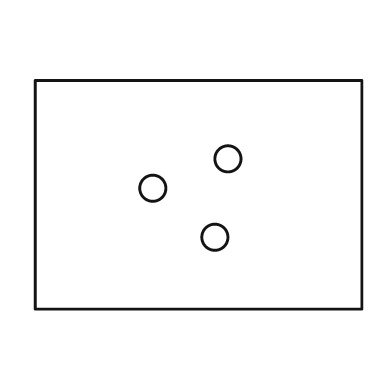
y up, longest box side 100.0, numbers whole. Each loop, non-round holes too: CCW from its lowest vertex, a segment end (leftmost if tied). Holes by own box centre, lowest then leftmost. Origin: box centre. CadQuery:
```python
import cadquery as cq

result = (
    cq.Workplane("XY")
    .moveTo(-50.0, -35.0)
    .lineTo(50.0, -35.0)
    .lineTo(50.0, 35.0)
    .lineTo(-50.0, 35.0)
    .close()
    .moveTo(5.0, -13.0)
    .circle(4.0)
    .moveTo(-14.0, 2.0)
    .circle(4.0)
    .moveTo(9.0, 11.0)
    .circle(4.0)
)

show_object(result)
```